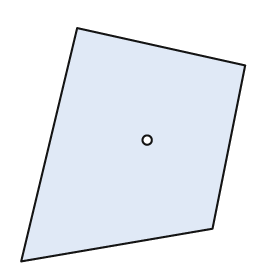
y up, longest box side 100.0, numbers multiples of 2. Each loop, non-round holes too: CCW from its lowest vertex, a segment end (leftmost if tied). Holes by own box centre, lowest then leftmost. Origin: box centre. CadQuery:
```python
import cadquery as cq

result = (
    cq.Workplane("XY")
    .moveTo(-48.0, -50.0)
    .lineTo(34.0, -36.0)
    .lineTo(48.0, 34.0)
    .lineTo(-24.0, 50.0)
    .close()
    .moveTo(6.0, 2.0)
    .circle(2.0)
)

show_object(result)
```